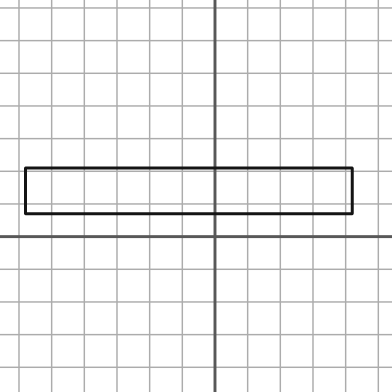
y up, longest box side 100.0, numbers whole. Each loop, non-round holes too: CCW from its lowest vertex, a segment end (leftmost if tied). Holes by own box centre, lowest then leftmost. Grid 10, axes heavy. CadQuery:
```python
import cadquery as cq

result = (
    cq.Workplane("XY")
    .moveTo(-58.0, 7.0)
    .lineTo(42.0, 7.0)
    .lineTo(42.0, 21.0)
    .lineTo(-58.0, 21.0)
    .close()
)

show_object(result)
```